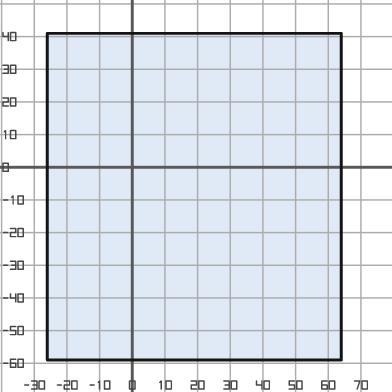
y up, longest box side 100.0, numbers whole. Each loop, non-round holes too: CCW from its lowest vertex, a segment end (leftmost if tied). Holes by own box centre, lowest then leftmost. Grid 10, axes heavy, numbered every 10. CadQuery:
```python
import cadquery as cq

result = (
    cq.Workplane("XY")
    .moveTo(-26.0, -59.0)
    .lineTo(64.0, -59.0)
    .lineTo(64.0, 41.0)
    .lineTo(-26.0, 41.0)
    .close()
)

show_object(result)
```